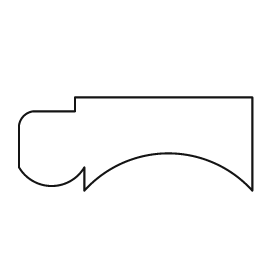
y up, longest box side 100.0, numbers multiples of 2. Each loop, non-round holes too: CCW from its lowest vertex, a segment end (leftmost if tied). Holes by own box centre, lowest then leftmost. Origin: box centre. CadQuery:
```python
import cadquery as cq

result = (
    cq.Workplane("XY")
    .moveTo(-22.0, -20.0)
    .threePointArc((14.0, -4.0), (50.0, -20.0))
    .lineTo(50.0, 20.0)
    .lineTo(-26.0, 20.0)
    .lineTo(-26.0, 14.0)
    .lineTo(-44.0, 14.0)
    .threePointArc((-48.0, 12.0), (-50.0, 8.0))
    .lineTo(-50.0, -10.0)
    .threePointArc((-36.0, -18.0), (-22.0, -10.0))
    .close()
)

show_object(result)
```